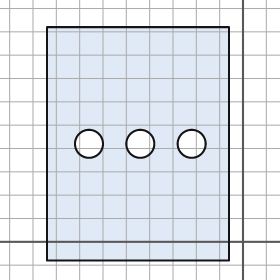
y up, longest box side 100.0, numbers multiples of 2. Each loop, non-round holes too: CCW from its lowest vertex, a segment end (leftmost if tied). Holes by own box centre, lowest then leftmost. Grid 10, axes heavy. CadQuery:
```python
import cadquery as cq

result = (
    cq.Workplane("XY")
    .moveTo(-84.0, -8.0)
    .lineTo(-6.0, -8.0)
    .lineTo(-6.0, 92.0)
    .lineTo(-84.0, 92.0)
    .close()
    .moveTo(-66.0, 42.0)
    .circle(6.0)
    .moveTo(-44.0, 42.0)
    .circle(6.0)
    .moveTo(-22.0, 42.0)
    .circle(6.0)
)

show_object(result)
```